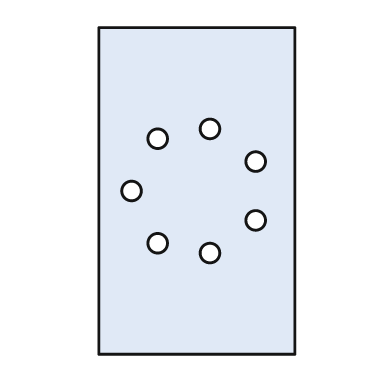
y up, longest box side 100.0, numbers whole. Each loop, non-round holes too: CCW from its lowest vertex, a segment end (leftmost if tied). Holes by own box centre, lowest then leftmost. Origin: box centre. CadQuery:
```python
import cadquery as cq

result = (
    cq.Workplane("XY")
    .moveTo(-30.0, -50.0)
    .lineTo(30.0, -50.0)
    .lineTo(30.0, 50.0)
    .lineTo(-30.0, 50.0)
    .close()
    .moveTo(4.0, -19.0)
    .circle(3.0)
    .moveTo(-12.0, -16.0)
    .circle(3.0)
    .moveTo(18.0, -9.0)
    .circle(3.0)
    .moveTo(-20.0, 0.0)
    .circle(3.0)
    .moveTo(18.0, 9.0)
    .circle(3.0)
    .moveTo(-12.0, 16.0)
    .circle(3.0)
    .moveTo(4.0, 19.0)
    .circle(3.0)
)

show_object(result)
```